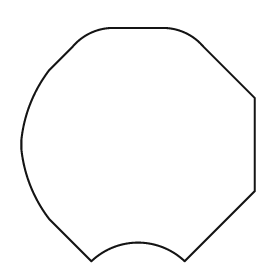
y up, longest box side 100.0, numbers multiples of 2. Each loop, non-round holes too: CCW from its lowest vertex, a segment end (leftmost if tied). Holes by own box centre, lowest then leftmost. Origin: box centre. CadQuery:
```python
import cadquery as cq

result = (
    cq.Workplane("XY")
    .moveTo(-20.0, -50.0)
    .threePointArc((0.0, -42.0), (20.0, -50.0))
    .lineTo(50.0, -20.0)
    .lineTo(50.0, 20.0)
    .lineTo(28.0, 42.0)
    .threePointArc((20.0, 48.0), (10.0, 50.0))
    .lineTo(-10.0, 50.0)
    .threePointArc((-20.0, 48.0), (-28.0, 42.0))
    .lineTo(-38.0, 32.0)
    .threePointArc((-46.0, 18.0), (-50.0, 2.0))
    .lineTo(-50.0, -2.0)
    .threePointArc((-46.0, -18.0), (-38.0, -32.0))
    .close()
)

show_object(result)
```